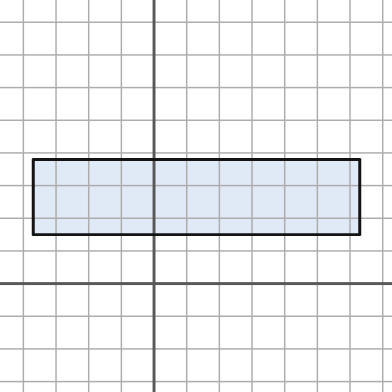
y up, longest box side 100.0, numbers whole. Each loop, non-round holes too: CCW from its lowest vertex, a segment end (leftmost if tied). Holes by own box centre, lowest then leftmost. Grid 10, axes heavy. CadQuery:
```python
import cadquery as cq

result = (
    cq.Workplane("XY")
    .moveTo(-37.0, 15.0)
    .lineTo(63.0, 15.0)
    .lineTo(63.0, 38.0)
    .lineTo(-37.0, 38.0)
    .close()
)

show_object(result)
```